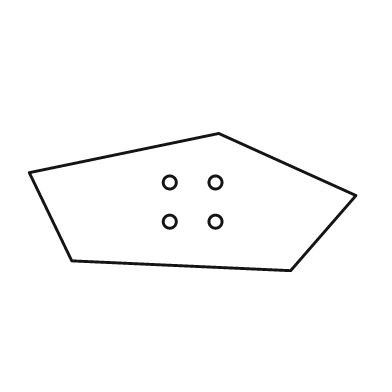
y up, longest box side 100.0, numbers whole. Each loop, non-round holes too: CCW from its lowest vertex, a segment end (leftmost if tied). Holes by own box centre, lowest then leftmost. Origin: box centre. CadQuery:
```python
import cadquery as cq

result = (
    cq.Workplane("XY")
    .moveTo(30.0, -21.0)
    .lineTo(50.0, 2.0)
    .lineTo(8.0, 21.0)
    .lineTo(-50.0, 9.0)
    .lineTo(-37.0, -18.0)
    .close()
    .moveTo(-7.0, -6.0)
    .circle(2.0)
    .moveTo(7.0, -6.0)
    .circle(2.0)
    .moveTo(-7.0, 6.0)
    .circle(2.0)
    .moveTo(7.0, 6.0)
    .circle(2.0)
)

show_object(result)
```